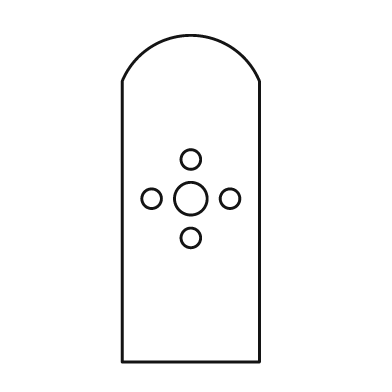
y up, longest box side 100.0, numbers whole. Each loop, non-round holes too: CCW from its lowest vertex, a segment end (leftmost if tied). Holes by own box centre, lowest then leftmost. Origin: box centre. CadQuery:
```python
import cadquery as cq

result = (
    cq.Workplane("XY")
    .moveTo(-21.0, -50.0)
    .lineTo(21.0, -50.0)
    .lineTo(21.0, 36.0)
    .threePointArc((0.0, 50.0), (-21.0, 36.0))
    .close()
    .moveTo(0.0, -12.0)
    .circle(3.0)
    .moveTo(-12.0, 0.0)
    .circle(3.0)
    .moveTo(0.0, 0.0)
    .circle(5.0)
    .moveTo(12.0, 0.0)
    .circle(3.0)
    .moveTo(0.0, 12.0)
    .circle(3.0)
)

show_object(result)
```